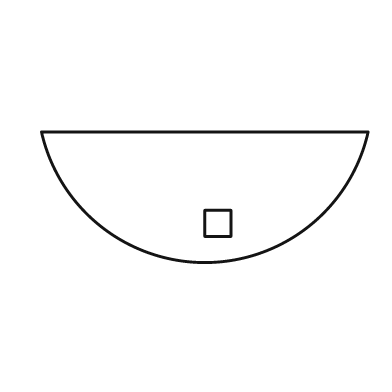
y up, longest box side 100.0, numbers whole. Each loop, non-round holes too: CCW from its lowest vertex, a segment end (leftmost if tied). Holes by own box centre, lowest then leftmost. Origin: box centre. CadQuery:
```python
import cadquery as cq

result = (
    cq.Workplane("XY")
    .moveTo(-50.0, 20.0)
    .threePointArc((0.0, -20.0), (50.0, 20.0))
    .close()
    .moveTo(0.0, -12.0)
    .lineTo(8.0, -12.0)
    .lineTo(8.0, -4.0)
    .lineTo(0.0, -4.0)
    .close()
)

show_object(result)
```